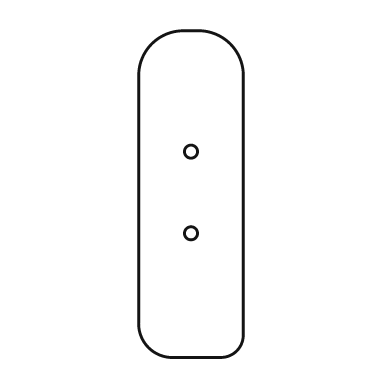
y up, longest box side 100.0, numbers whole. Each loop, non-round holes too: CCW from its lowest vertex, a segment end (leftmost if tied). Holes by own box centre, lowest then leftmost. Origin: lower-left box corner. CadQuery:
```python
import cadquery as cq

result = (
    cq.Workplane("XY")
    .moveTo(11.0, 0.0)
    .lineTo(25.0, 0.0)
    .threePointArc((30.0, 2.0), (32.0, 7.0))
    .lineTo(32.0, 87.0)
    .threePointArc((28.0, 96.0), (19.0, 100.0))
    .lineTo(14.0, 100.0)
    .threePointArc((4.0, 96.0), (0.0, 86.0))
    .lineTo(0.0, 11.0)
    .threePointArc((3.0, 3.0), (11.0, 0.0))
    .close()
    .moveTo(16.0, 38.0)
    .circle(2.0)
    .moveTo(16.0, 63.0)
    .circle(2.0)
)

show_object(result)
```